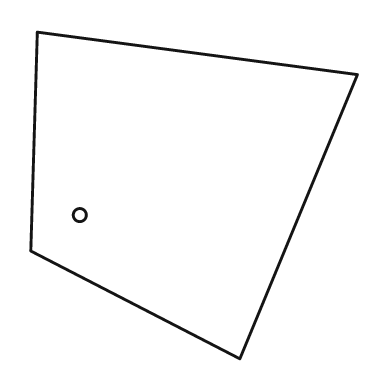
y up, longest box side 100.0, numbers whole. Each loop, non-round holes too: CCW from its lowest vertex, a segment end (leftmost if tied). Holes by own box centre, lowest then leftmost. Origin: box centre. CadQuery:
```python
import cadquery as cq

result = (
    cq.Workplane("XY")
    .moveTo(14.0, -50.0)
    .lineTo(50.0, 37.0)
    .lineTo(-48.0, 50.0)
    .lineTo(-50.0, -17.0)
    .close()
    .moveTo(-35.0, -6.0)
    .circle(2.0)
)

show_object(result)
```